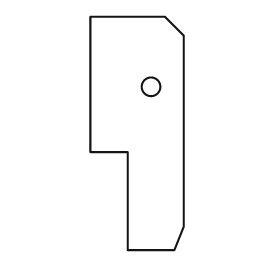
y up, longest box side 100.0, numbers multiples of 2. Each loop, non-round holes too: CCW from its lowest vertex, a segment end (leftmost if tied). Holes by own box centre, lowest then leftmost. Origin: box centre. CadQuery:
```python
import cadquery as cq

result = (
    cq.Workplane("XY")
    .moveTo(-4.0, -50.0)
    .lineTo(16.0, -50.0)
    .lineTo(20.0, -40.0)
    .lineTo(20.0, 42.0)
    .lineTo(12.0, 50.0)
    .lineTo(-20.0, 50.0)
    .lineTo(-20.0, -8.0)
    .lineTo(-4.0, -8.0)
    .close()
    .moveTo(6.0, 20.0)
    .circle(4.0)
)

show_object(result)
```